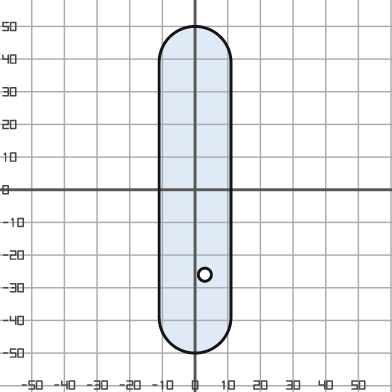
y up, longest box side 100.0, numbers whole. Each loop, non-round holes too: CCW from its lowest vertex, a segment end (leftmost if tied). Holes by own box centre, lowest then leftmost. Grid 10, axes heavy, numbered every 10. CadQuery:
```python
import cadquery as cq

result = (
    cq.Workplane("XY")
    .moveTo(-11.0, -39.0)
    .threePointArc((0.0, -50.0), (11.0, -39.0))
    .lineTo(11.0, 39.0)
    .threePointArc((0.0, 50.0), (-11.0, 39.0))
    .close()
    .moveTo(3.0, -26.0)
    .circle(2.0)
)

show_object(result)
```